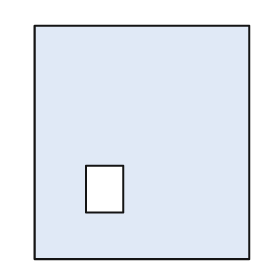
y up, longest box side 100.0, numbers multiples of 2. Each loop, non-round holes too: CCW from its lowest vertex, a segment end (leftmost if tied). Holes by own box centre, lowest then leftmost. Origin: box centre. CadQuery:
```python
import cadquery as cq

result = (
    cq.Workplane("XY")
    .moveTo(-46.0, -50.0)
    .lineTo(46.0, -50.0)
    .lineTo(46.0, 50.0)
    .lineTo(-46.0, 50.0)
    .close()
    .moveTo(-24.0, -30.0)
    .lineTo(-8.0, -30.0)
    .lineTo(-8.0, -10.0)
    .lineTo(-24.0, -10.0)
    .close()
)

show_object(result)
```